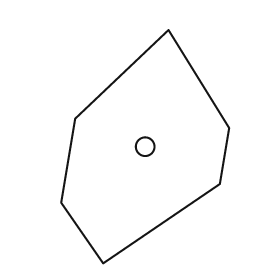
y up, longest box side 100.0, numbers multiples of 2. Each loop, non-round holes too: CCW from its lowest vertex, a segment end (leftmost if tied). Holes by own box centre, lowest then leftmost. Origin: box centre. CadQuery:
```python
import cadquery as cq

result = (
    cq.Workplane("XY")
    .moveTo(-18.0, -50.0)
    .lineTo(32.0, -16.0)
    .lineTo(36.0, 8.0)
    .lineTo(10.0, 50.0)
    .lineTo(-30.0, 12.0)
    .lineTo(-36.0, -24.0)
    .close()
    .moveTo(0.0, 0.0)
    .circle(4.0)
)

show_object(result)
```